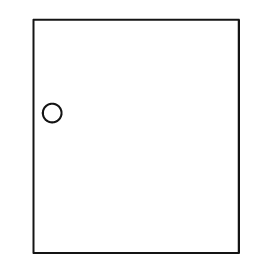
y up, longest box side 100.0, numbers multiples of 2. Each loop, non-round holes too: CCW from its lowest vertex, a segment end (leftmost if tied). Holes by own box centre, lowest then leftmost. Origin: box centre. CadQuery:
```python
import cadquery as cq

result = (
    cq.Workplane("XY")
    .moveTo(-44.0, -50.0)
    .lineTo(44.0, -50.0)
    .lineTo(44.0, 50.0)
    .lineTo(-44.0, 50.0)
    .close()
    .moveTo(-36.0, 10.0)
    .circle(4.0)
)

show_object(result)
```